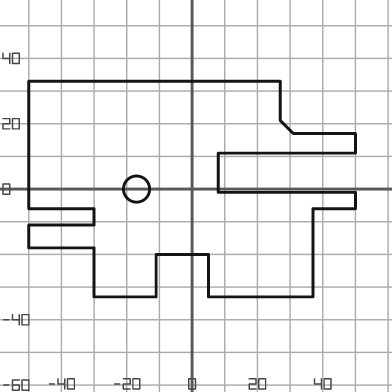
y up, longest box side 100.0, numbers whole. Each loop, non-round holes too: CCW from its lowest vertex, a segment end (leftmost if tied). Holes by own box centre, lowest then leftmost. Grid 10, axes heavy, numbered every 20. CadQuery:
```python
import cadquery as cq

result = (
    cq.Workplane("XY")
    .moveTo(-30.0, -33.0)
    .lineTo(-11.0, -33.0)
    .lineTo(-11.0, -20.0)
    .lineTo(5.0, -20.0)
    .lineTo(5.0, -33.0)
    .lineTo(37.0, -33.0)
    .lineTo(37.0, -6.0)
    .lineTo(50.0, -6.0)
    .lineTo(50.0, -1.0)
    .lineTo(8.0, -1.0)
    .lineTo(8.0, 11.0)
    .lineTo(50.0, 11.0)
    .lineTo(50.0, 17.0)
    .lineTo(31.0, 17.0)
    .lineTo(27.0, 21.0)
    .lineTo(27.0, 33.0)
    .lineTo(-50.0, 33.0)
    .lineTo(-50.0, -6.0)
    .lineTo(-30.0, -6.0)
    .lineTo(-30.0, -11.0)
    .lineTo(-50.0, -11.0)
    .lineTo(-50.0, -18.0)
    .lineTo(-30.0, -18.0)
    .close()
    .moveTo(-17.0, 0.0)
    .circle(4.0)
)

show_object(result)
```